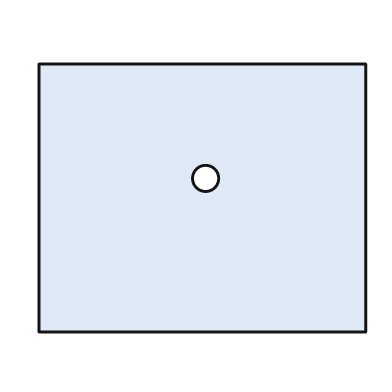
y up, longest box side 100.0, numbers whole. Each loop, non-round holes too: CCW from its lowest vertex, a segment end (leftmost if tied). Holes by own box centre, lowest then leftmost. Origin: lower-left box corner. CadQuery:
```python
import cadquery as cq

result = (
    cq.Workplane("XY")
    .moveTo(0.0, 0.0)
    .lineTo(100.0, 0.0)
    .lineTo(100.0, 82.0)
    .lineTo(0.0, 82.0)
    .close()
    .moveTo(51.0, 47.0)
    .circle(4.0)
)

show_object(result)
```